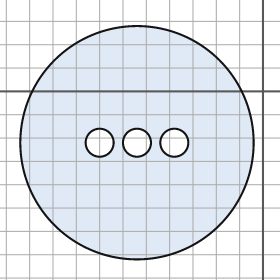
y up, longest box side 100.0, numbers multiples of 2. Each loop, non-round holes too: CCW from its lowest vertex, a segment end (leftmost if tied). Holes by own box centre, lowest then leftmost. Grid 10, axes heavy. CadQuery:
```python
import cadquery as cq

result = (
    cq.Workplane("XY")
    .moveTo(-54.0, -22.0)
    .circle(50.0)
    .moveTo(-70.0, -22.0)
    .circle(6.0)
    .moveTo(-54.0, -22.0)
    .circle(6.0)
    .moveTo(-38.0, -22.0)
    .circle(6.0)
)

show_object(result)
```